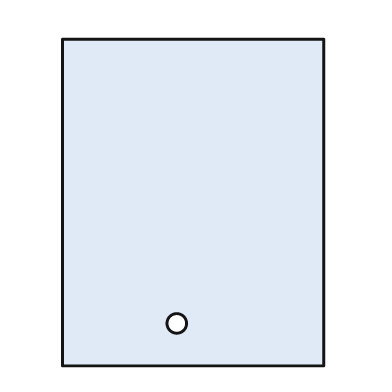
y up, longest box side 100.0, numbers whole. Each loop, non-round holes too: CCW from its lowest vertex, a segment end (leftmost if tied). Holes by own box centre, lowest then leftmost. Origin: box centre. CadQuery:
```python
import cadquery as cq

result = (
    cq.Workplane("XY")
    .moveTo(-40.0, -50.0)
    .lineTo(40.0, -50.0)
    .lineTo(40.0, 50.0)
    .lineTo(-40.0, 50.0)
    .close()
    .moveTo(-5.0, -37.0)
    .circle(3.0)
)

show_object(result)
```